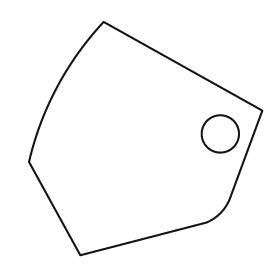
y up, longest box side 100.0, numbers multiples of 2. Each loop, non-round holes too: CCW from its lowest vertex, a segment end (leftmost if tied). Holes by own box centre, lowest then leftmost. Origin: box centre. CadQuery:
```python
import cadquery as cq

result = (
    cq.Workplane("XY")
    .moveTo(-28.0, -50.0)
    .lineTo(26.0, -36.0)
    .threePointArc((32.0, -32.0), (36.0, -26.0))
    .lineTo(50.0, 12.0)
    .lineTo(-18.0, 50.0)
    .threePointArc((-38.0, 22.0), (-50.0, -10.0))
    .close()
    .moveTo(32.0, 2.0)
    .circle(8.0)
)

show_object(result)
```